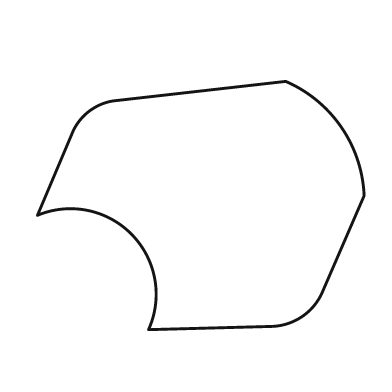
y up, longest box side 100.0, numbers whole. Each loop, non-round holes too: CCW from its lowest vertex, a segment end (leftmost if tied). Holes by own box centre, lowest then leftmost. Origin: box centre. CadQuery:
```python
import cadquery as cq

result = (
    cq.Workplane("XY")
    .moveTo(-16.0, -38.0)
    .lineTo(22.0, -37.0)
    .threePointArc((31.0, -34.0), (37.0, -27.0))
    .lineTo(50.0, 3.0)
    .threePointArc((43.0, 24.0), (26.0, 38.0))
    .lineTo(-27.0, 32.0)
    .threePointArc((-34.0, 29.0), (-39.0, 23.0))
    .lineTo(-50.0, -3.0)
    .threePointArc((-21.0, -9.0), (-16.0, -38.0))
    .close()
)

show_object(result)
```